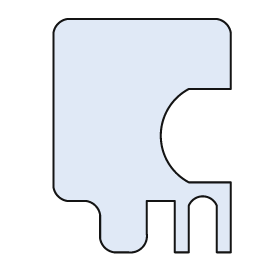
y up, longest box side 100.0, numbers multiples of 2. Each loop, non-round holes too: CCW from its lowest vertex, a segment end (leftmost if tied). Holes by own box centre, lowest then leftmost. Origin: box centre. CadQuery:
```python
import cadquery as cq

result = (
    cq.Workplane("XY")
    .moveTo(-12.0, -50.0)
    .lineTo(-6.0, -50.0)
    .threePointArc((0.0, -48.0), (2.0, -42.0))
    .lineTo(2.0, -28.0)
    .lineTo(14.0, -28.0)
    .lineTo(14.0, -50.0)
    .lineTo(20.0, -50.0)
    .lineTo(20.0, -30.0)
    .threePointArc((26.0, -26.0), (32.0, -30.0))
    .lineTo(32.0, -50.0)
    .lineTo(38.0, -50.0)
    .lineTo(38.0, -20.0)
    .lineTo(20.0, -20.0)
    .threePointArc((8.0, 0.0), (20.0, 20.0))
    .lineTo(38.0, 20.0)
    .lineTo(38.0, 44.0)
    .threePointArc((36.0, 48.0), (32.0, 50.0))
    .lineTo(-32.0, 50.0)
    .threePointArc((-36.0, 48.0), (-38.0, 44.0))
    .lineTo(-38.0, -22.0)
    .threePointArc((-36.0, -26.0), (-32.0, -28.0))
    .lineTo(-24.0, -28.0)
    .threePointArc((-20.0, -30.0), (-18.0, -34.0))
    .lineTo(-18.0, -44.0)
    .threePointArc((-16.0, -48.0), (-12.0, -50.0))
    .close()
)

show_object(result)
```